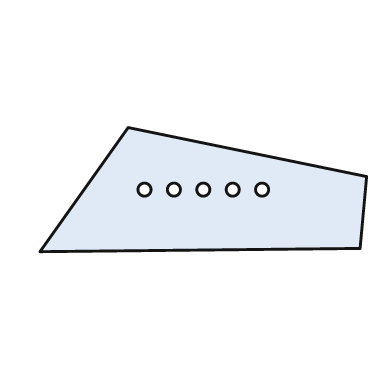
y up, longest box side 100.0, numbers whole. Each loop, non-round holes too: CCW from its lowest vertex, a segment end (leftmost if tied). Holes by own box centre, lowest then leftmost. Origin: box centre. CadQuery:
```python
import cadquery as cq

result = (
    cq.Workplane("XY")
    .moveTo(-50.0, -19.0)
    .lineTo(48.0, -18.0)
    .lineTo(50.0, 4.0)
    .lineTo(-23.0, 19.0)
    .close()
    .moveTo(-18.0, 0.0)
    .circle(2.0)
    .moveTo(-9.0, 0.0)
    .circle(2.0)
    .moveTo(0.0, 0.0)
    .circle(2.0)
    .moveTo(9.0, 0.0)
    .circle(2.0)
    .moveTo(18.0, 0.0)
    .circle(2.0)
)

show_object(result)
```